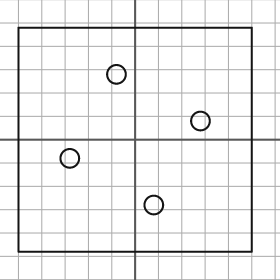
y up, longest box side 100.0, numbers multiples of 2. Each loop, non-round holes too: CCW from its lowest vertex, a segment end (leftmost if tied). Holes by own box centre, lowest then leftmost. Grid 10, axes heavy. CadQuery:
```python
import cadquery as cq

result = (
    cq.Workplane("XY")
    .moveTo(-50.0, -48.0)
    .lineTo(50.0, -48.0)
    .lineTo(50.0, 48.0)
    .lineTo(-50.0, 48.0)
    .close()
    .moveTo(8.0, -28.0)
    .circle(4.0)
    .moveTo(-28.0, -8.0)
    .circle(4.0)
    .moveTo(28.0, 8.0)
    .circle(4.0)
    .moveTo(-8.0, 28.0)
    .circle(4.0)
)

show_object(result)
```